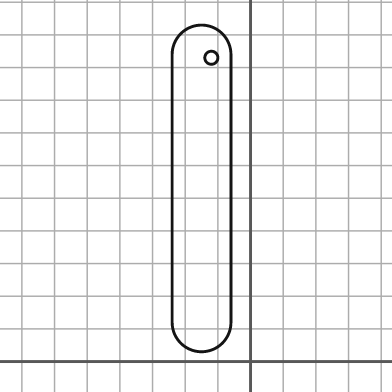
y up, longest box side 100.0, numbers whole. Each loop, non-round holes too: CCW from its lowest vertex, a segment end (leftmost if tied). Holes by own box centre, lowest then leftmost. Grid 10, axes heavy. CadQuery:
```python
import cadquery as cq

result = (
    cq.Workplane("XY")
    .moveTo(-24.0, 12.0)
    .threePointArc((-15.0, 3.0), (-6.0, 12.0))
    .lineTo(-6.0, 94.0)
    .threePointArc((-15.0, 103.0), (-24.0, 94.0))
    .close()
    .moveTo(-12.0, 93.0)
    .circle(2.0)
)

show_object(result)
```